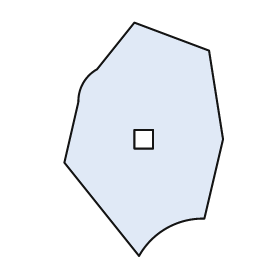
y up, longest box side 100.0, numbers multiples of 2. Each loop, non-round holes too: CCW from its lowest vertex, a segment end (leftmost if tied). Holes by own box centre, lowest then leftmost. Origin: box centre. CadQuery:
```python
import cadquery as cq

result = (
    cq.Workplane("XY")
    .moveTo(-2.0, -50.0)
    .threePointArc((10.0, -38.0), (26.0, -34.0))
    .lineTo(34.0, 0.0)
    .lineTo(28.0, 38.0)
    .lineTo(-4.0, 50.0)
    .lineTo(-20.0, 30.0)
    .threePointArc((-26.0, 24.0), (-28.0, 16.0))
    .lineTo(-34.0, -10.0)
    .close()
    .moveTo(-4.0, -4.0)
    .lineTo(4.0, -4.0)
    .lineTo(4.0, 4.0)
    .lineTo(-4.0, 4.0)
    .close()
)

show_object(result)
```